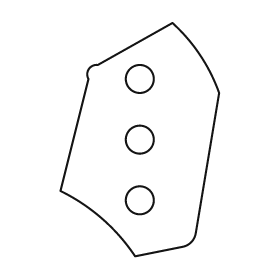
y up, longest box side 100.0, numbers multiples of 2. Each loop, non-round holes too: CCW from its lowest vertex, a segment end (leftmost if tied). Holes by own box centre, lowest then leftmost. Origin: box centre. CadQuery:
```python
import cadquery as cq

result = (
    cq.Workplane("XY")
    .moveTo(-2.0, -50.0)
    .lineTo(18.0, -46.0)
    .threePointArc((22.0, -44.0), (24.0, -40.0))
    .lineTo(34.0, 20.0)
    .threePointArc((26.0, 36.0), (14.0, 50.0))
    .lineTo(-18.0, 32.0)
    .threePointArc((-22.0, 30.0), (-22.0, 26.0))
    .lineTo(-34.0, -22.0)
    .threePointArc((-16.0, -34.0), (-2.0, -50.0))
    .close()
    .moveTo(0.0, -26.0)
    .circle(6.0)
    .moveTo(0.0, 0.0)
    .circle(6.0)
    .moveTo(0.0, 26.0)
    .circle(6.0)
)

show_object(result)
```